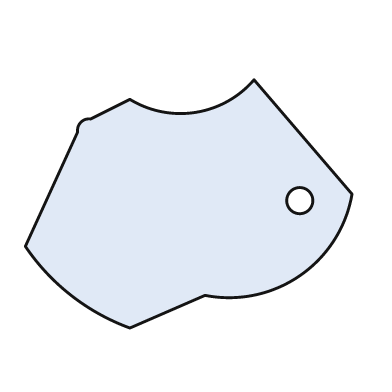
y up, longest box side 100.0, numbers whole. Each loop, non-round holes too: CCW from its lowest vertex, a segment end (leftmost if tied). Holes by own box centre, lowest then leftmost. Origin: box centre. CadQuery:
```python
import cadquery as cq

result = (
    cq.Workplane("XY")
    .moveTo(-18.0, -38.0)
    .lineTo(5.0, -28.0)
    .threePointArc((34.0, -22.0), (50.0, 3.0))
    .lineTo(20.0, 38.0)
    .threePointArc((2.0, 28.0), (-18.0, 32.0))
    .lineTo(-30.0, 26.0)
    .threePointArc((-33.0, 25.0), (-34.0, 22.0))
    .lineTo(-50.0, -13.0)
    .threePointArc((-36.0, -28.0), (-18.0, -38.0))
    .close()
    .moveTo(34.0, 1.0)
    .circle(4.0)
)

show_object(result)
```